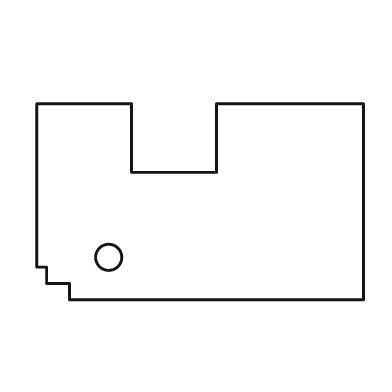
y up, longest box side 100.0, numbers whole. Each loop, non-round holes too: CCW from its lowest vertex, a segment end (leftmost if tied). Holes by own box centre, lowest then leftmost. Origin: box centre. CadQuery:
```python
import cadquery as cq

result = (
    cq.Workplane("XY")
    .moveTo(-40.0, -30.0)
    .lineTo(50.0, -30.0)
    .lineTo(50.0, 30.0)
    .lineTo(5.0, 30.0)
    .lineTo(5.0, 9.0)
    .lineTo(-21.0, 9.0)
    .lineTo(-21.0, 30.0)
    .lineTo(-50.0, 30.0)
    .lineTo(-50.0, -20.0)
    .lineTo(-47.0, -20.0)
    .lineTo(-47.0, -25.0)
    .lineTo(-40.0, -25.0)
    .close()
    .moveTo(-28.0, -17.0)
    .circle(4.0)
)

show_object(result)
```